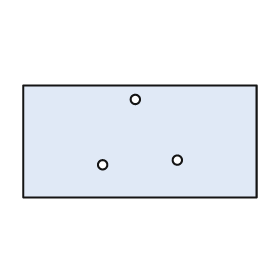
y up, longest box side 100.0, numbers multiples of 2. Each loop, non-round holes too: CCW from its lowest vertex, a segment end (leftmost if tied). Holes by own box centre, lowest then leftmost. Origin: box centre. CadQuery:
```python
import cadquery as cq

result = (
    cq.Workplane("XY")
    .moveTo(-50.0, -24.0)
    .lineTo(50.0, -24.0)
    .lineTo(50.0, 24.0)
    .lineTo(-50.0, 24.0)
    .close()
    .moveTo(-16.0, -10.0)
    .circle(2.0)
    .moveTo(16.0, -8.0)
    .circle(2.0)
    .moveTo(-2.0, 18.0)
    .circle(2.0)
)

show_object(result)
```